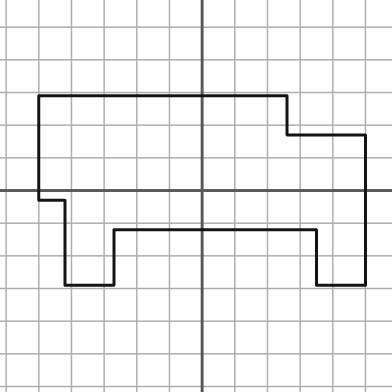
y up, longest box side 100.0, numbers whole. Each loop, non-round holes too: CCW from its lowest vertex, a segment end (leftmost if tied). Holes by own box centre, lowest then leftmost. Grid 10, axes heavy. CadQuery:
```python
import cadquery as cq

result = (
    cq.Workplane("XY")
    .moveTo(-42.0, -29.0)
    .lineTo(-27.0, -29.0)
    .lineTo(-27.0, -12.0)
    .lineTo(35.0, -12.0)
    .lineTo(35.0, -29.0)
    .lineTo(50.0, -29.0)
    .lineTo(50.0, 17.0)
    .lineTo(26.0, 17.0)
    .lineTo(26.0, 29.0)
    .lineTo(-50.0, 29.0)
    .lineTo(-50.0, -3.0)
    .lineTo(-42.0, -3.0)
    .close()
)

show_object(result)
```